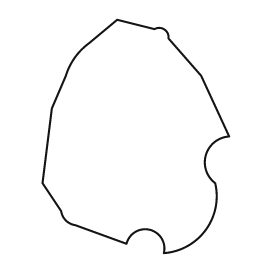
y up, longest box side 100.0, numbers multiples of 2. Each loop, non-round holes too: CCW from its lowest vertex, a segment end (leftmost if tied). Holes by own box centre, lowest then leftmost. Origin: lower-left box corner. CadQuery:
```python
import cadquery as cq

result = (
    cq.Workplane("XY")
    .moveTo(52.0, 0.0)
    .threePointArc((70.0, 10.0), (74.0, 30.0))
    .threePointArc((70.0, 42.0), (80.0, 50.0))
    .lineTo(68.0, 76.0)
    .lineTo(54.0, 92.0)
    .threePointArc((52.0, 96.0), (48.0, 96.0))
    .lineTo(32.0, 100.0)
    .lineTo(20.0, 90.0)
    .threePointArc((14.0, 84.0), (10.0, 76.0))
    .lineTo(4.0, 62.0)
    .lineTo(0.0, 30.0)
    .lineTo(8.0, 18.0)
    .threePointArc((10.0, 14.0), (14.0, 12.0))
    .lineTo(36.0, 4.0)
    .threePointArc((46.0, 10.0), (52.0, 0.0))
    .close()
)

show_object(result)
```